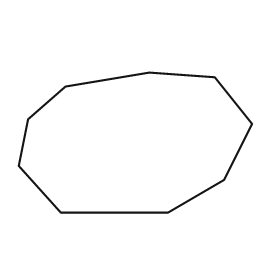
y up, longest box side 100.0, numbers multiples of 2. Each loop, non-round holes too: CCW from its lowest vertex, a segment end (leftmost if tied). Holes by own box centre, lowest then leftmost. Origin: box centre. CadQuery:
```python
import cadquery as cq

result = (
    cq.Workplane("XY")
    .moveTo(-32.0, -30.0)
    .lineTo(14.0, -30.0)
    .lineTo(38.0, -16.0)
    .lineTo(50.0, 8.0)
    .lineTo(34.0, 28.0)
    .lineTo(6.0, 30.0)
    .lineTo(-30.0, 24.0)
    .lineTo(-46.0, 10.0)
    .lineTo(-50.0, -10.0)
    .close()
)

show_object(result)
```